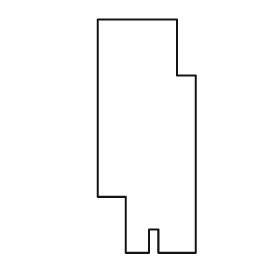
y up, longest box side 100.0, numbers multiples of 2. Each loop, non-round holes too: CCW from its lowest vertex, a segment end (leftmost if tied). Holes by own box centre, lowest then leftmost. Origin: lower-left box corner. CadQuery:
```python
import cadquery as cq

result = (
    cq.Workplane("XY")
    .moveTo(12.0, 0.0)
    .lineTo(22.0, 0.0)
    .lineTo(22.0, 10.0)
    .lineTo(26.0, 10.0)
    .lineTo(26.0, 0.0)
    .lineTo(42.0, 0.0)
    .lineTo(42.0, 76.0)
    .lineTo(34.0, 76.0)
    .lineTo(34.0, 100.0)
    .lineTo(0.0, 100.0)
    .lineTo(0.0, 24.0)
    .lineTo(12.0, 24.0)
    .close()
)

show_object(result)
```